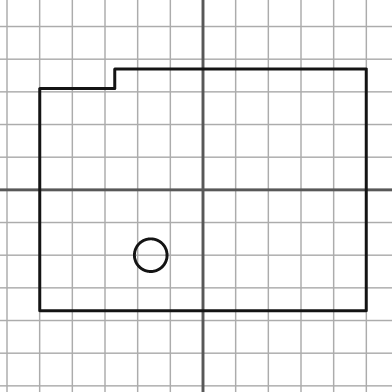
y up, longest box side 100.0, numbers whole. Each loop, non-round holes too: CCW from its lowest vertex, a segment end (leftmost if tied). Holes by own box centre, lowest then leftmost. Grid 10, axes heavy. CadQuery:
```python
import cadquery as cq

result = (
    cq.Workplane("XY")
    .moveTo(-50.0, -37.0)
    .lineTo(50.0, -37.0)
    .lineTo(50.0, 37.0)
    .lineTo(-27.0, 37.0)
    .lineTo(-27.0, 31.0)
    .lineTo(-50.0, 31.0)
    .close()
    .moveTo(-16.0, -20.0)
    .circle(5.0)
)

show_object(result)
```